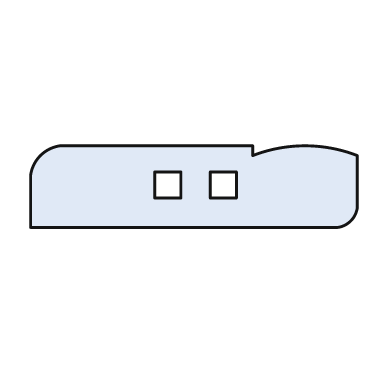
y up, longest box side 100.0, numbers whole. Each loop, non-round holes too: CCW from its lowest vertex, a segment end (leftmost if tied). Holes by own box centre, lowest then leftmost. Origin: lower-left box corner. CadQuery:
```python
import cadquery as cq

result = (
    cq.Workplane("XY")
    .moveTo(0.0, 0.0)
    .lineTo(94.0, 0.0)
    .threePointArc((98.0, 2.0), (100.0, 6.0))
    .lineTo(100.0, 22.0)
    .threePointArc((84.0, 25.0), (68.0, 22.0))
    .lineTo(68.0, 25.0)
    .lineTo(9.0, 25.0)
    .threePointArc((3.0, 22.0), (0.0, 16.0))
    .close()
    .moveTo(38.0, 9.0)
    .lineTo(46.0, 9.0)
    .lineTo(46.0, 17.0)
    .lineTo(38.0, 17.0)
    .close()
    .moveTo(55.0, 9.0)
    .lineTo(63.0, 9.0)
    .lineTo(63.0, 17.0)
    .lineTo(55.0, 17.0)
    .close()
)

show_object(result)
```